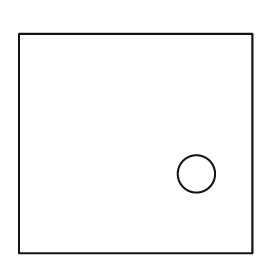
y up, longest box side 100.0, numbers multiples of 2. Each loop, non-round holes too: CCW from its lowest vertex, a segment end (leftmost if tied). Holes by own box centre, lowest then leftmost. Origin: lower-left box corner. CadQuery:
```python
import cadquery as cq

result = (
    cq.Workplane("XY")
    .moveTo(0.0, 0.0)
    .lineTo(100.0, 0.0)
    .lineTo(100.0, 94.0)
    .lineTo(0.0, 94.0)
    .close()
    .moveTo(76.0, 34.0)
    .circle(8.0)
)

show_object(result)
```